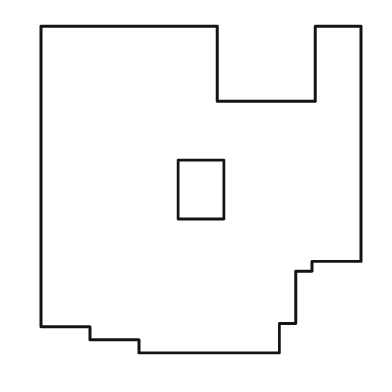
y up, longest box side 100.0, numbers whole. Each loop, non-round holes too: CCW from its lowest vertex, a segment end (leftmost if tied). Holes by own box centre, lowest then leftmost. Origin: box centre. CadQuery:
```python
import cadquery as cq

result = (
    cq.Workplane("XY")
    .moveTo(-19.0, -50.0)
    .lineTo(24.0, -50.0)
    .lineTo(24.0, -41.0)
    .lineTo(29.0, -41.0)
    .lineTo(29.0, -25.0)
    .lineTo(34.0, -25.0)
    .lineTo(34.0, -22.0)
    .lineTo(49.0, -22.0)
    .lineTo(49.0, 50.0)
    .lineTo(35.0, 50.0)
    .lineTo(35.0, 27.0)
    .lineTo(5.0, 27.0)
    .lineTo(5.0, 50.0)
    .lineTo(-49.0, 50.0)
    .lineTo(-49.0, -42.0)
    .lineTo(-34.0, -42.0)
    .lineTo(-34.0, -46.0)
    .lineTo(-19.0, -46.0)
    .close()
    .moveTo(-7.0, -9.0)
    .lineTo(7.0, -9.0)
    .lineTo(7.0, 9.0)
    .lineTo(-7.0, 9.0)
    .close()
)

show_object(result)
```